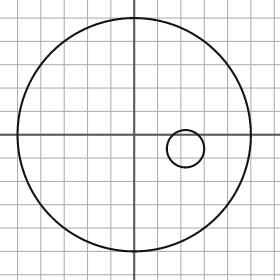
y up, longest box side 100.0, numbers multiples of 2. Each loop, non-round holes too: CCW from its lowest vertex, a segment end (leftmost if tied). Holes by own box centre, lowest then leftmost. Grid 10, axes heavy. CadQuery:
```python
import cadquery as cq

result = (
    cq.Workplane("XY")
    .moveTo(0.0, 0.0)
    .circle(50.0)
    .moveTo(22.0, -6.0)
    .circle(8.0)
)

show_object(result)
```